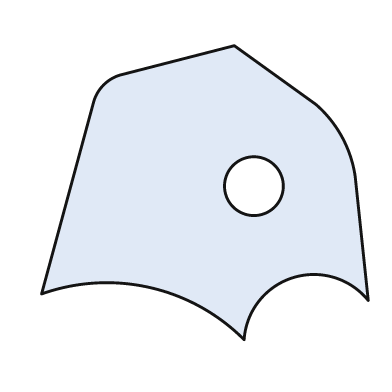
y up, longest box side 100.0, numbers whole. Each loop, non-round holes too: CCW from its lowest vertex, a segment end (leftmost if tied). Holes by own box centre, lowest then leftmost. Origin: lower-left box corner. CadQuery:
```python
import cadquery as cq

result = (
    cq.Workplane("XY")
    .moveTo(62.0, 0.0)
    .threePointArc((77.0, 19.0), (100.0, 12.0))
    .lineTo(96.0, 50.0)
    .threePointArc((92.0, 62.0), (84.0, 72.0))
    .lineTo(59.0, 90.0)
    .lineTo(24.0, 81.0)
    .threePointArc((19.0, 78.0), (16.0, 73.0))
    .lineTo(0.0, 14.0)
    .threePointArc((33.0, 16.0), (62.0, 0.0))
    .close()
    .moveTo(65.0, 47.0)
    .circle(9.0)
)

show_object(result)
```